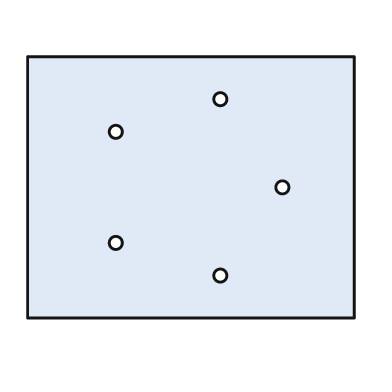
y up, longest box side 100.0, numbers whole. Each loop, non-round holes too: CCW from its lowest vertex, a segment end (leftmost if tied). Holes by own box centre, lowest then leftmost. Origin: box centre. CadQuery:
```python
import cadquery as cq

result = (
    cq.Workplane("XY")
    .moveTo(-50.0, -40.0)
    .lineTo(50.0, -40.0)
    .lineTo(50.0, 40.0)
    .lineTo(-50.0, 40.0)
    .close()
    .moveTo(9.0, -27.0)
    .circle(2.0)
    .moveTo(-23.0, -17.0)
    .circle(2.0)
    .moveTo(28.0, 0.0)
    .circle(2.0)
    .moveTo(-23.0, 17.0)
    .circle(2.0)
    .moveTo(9.0, 27.0)
    .circle(2.0)
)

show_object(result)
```